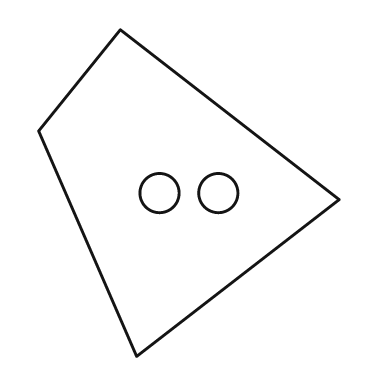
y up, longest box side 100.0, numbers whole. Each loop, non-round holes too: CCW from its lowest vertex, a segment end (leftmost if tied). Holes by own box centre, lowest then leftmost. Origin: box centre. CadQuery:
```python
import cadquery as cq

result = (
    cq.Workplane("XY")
    .moveTo(-16.0, -50.0)
    .lineTo(46.0, -2.0)
    .lineTo(-21.0, 50.0)
    .lineTo(-46.0, 19.0)
    .close()
    .moveTo(-9.0, 0.0)
    .circle(6.0)
    .moveTo(9.0, 0.0)
    .circle(6.0)
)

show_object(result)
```